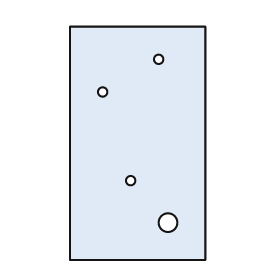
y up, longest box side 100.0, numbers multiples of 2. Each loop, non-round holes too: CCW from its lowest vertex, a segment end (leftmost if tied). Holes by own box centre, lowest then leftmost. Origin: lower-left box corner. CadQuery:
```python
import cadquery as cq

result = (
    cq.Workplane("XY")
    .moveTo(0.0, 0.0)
    .lineTo(58.0, 0.0)
    .lineTo(58.0, 100.0)
    .lineTo(0.0, 100.0)
    .close()
    .moveTo(42.0, 16.0)
    .circle(4.0)
    .moveTo(26.0, 34.0)
    .circle(2.0)
    .moveTo(14.0, 72.0)
    .circle(2.0)
    .moveTo(38.0, 86.0)
    .circle(2.0)
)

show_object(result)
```